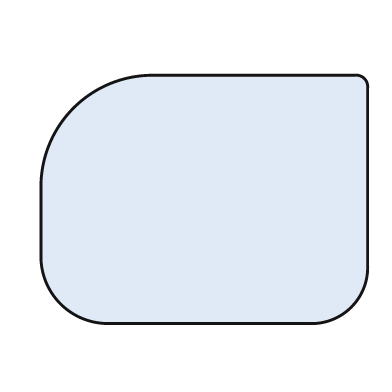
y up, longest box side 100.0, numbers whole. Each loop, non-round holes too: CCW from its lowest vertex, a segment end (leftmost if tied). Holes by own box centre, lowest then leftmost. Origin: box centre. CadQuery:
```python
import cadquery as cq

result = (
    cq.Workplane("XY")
    .moveTo(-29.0, -38.0)
    .lineTo(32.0, -38.0)
    .threePointArc((45.0, -33.0), (50.0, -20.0))
    .lineTo(50.0, 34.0)
    .threePointArc((49.0, 37.0), (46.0, 38.0))
    .lineTo(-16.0, 38.0)
    .threePointArc((-40.0, 28.0), (-50.0, 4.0))
    .lineTo(-50.0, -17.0)
    .threePointArc((-44.0, -32.0), (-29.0, -38.0))
    .close()
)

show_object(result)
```